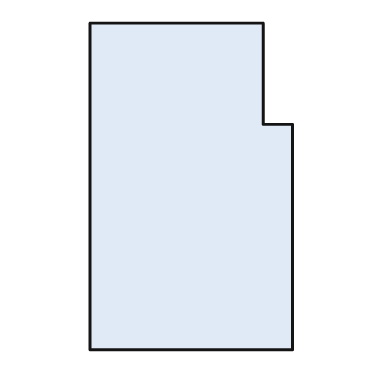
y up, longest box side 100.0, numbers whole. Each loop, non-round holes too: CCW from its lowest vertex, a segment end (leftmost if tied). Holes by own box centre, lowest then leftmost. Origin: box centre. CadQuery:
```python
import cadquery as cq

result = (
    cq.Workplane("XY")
    .moveTo(-31.0, -50.0)
    .lineTo(31.0, -50.0)
    .lineTo(31.0, 19.0)
    .lineTo(22.0, 19.0)
    .lineTo(22.0, 50.0)
    .lineTo(-31.0, 50.0)
    .close()
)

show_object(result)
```